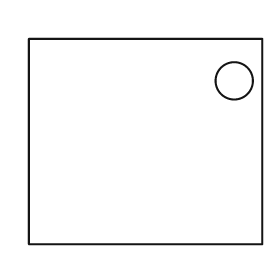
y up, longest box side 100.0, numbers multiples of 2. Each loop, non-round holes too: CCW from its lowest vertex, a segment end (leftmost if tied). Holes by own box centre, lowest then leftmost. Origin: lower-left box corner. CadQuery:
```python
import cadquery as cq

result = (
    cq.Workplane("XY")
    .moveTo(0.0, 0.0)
    .lineTo(100.0, 0.0)
    .lineTo(100.0, 88.0)
    .lineTo(0.0, 88.0)
    .close()
    .moveTo(88.0, 70.0)
    .circle(8.0)
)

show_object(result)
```